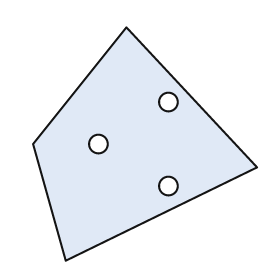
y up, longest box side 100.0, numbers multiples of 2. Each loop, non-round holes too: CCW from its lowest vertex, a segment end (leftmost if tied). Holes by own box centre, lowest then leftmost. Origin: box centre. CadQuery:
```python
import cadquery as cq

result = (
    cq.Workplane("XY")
    .moveTo(-34.0, -50.0)
    .lineTo(48.0, -10.0)
    .lineTo(-8.0, 50.0)
    .lineTo(-48.0, 0.0)
    .close()
    .moveTo(10.0, -18.0)
    .circle(4.0)
    .moveTo(-20.0, 0.0)
    .circle(4.0)
    .moveTo(10.0, 18.0)
    .circle(4.0)
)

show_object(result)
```